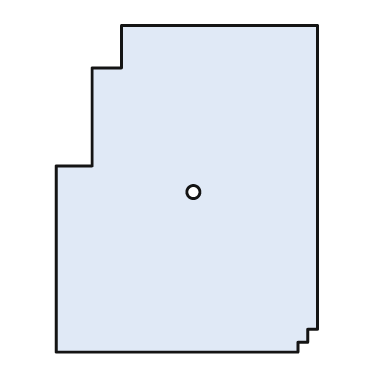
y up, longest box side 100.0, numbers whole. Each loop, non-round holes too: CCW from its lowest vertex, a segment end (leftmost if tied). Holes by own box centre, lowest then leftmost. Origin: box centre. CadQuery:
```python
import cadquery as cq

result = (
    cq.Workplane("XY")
    .moveTo(-40.0, -50.0)
    .lineTo(34.0, -50.0)
    .lineTo(34.0, -47.0)
    .lineTo(37.0, -47.0)
    .lineTo(37.0, -43.0)
    .lineTo(40.0, -43.0)
    .lineTo(40.0, 50.0)
    .lineTo(-20.0, 50.0)
    .lineTo(-20.0, 37.0)
    .lineTo(-29.0, 37.0)
    .lineTo(-29.0, 7.0)
    .lineTo(-40.0, 7.0)
    .close()
    .moveTo(2.0, -1.0)
    .circle(2.0)
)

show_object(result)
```